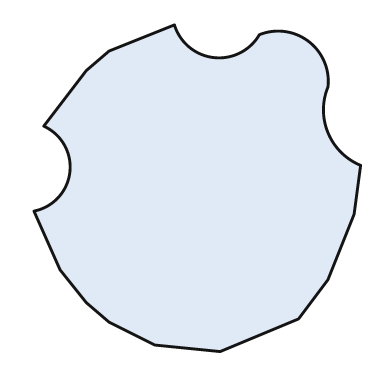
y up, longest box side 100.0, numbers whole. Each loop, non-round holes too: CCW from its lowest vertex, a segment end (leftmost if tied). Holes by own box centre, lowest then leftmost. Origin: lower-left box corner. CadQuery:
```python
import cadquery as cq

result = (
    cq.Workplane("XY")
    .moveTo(57.0, 0.0)
    .lineTo(81.0, 10.0)
    .lineTo(90.0, 22.0)
    .lineTo(98.0, 42.0)
    .lineTo(100.0, 57.0)
    .threePointArc((90.0, 67.0), (90.0, 81.0))
    .threePointArc((84.0, 95.0), (69.0, 97.0))
    .threePointArc((55.0, 90.0), (43.0, 100.0))
    .lineTo(23.0, 92.0)
    .lineTo(16.0, 86.0)
    .lineTo(3.0, 69.0)
    .threePointArc((11.0, 55.0), (0.0, 43.0))
    .lineTo(8.0, 25.0)
    .lineTo(16.0, 15.0)
    .lineTo(23.0, 9.0)
    .lineTo(37.0, 2.0)
    .close()
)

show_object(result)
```